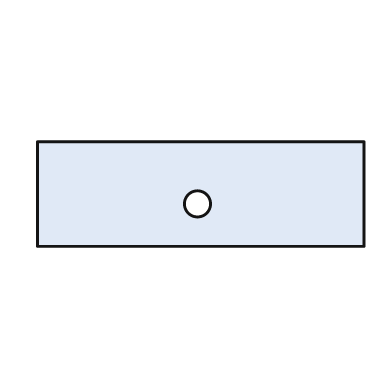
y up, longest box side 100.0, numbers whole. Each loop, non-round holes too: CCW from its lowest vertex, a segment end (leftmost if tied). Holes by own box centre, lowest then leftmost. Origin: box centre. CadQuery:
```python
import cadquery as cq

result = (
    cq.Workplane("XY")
    .moveTo(-50.0, -16.0)
    .lineTo(50.0, -16.0)
    .lineTo(50.0, 16.0)
    .lineTo(-50.0, 16.0)
    .close()
    .moveTo(-1.0, -3.0)
    .circle(4.0)
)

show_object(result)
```